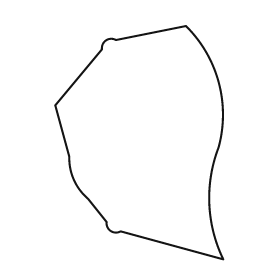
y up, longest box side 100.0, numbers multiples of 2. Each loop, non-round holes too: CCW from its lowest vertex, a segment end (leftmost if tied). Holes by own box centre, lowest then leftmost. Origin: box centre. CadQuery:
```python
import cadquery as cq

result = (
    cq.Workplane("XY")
    .moveTo(36.0, -50.0)
    .threePointArc((30.0, -26.0), (34.0, -2.0))
    .threePointArc((34.0, 26.0), (20.0, 50.0))
    .lineTo(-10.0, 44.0)
    .threePointArc((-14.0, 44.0), (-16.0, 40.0))
    .lineTo(-36.0, 16.0)
    .lineTo(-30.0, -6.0)
    .threePointArc((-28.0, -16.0), (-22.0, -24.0))
    .lineTo(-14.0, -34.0)
    .threePointArc((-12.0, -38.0), (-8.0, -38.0))
    .close()
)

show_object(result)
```